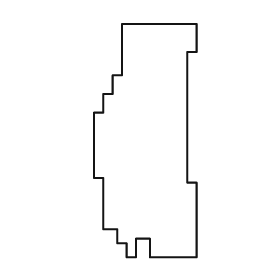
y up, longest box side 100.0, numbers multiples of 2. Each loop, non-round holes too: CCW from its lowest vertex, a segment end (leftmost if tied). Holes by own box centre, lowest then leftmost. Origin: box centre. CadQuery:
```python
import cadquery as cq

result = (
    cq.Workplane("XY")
    .moveTo(-8.0, -50.0)
    .lineTo(-4.0, -50.0)
    .lineTo(-4.0, -42.0)
    .lineTo(2.0, -42.0)
    .lineTo(2.0, -50.0)
    .lineTo(22.0, -50.0)
    .lineTo(22.0, -18.0)
    .lineTo(18.0, -18.0)
    .lineTo(18.0, 38.0)
    .lineTo(22.0, 38.0)
    .lineTo(22.0, 50.0)
    .lineTo(-10.0, 50.0)
    .lineTo(-10.0, 28.0)
    .lineTo(-14.0, 28.0)
    .lineTo(-14.0, 20.0)
    .lineTo(-18.0, 20.0)
    .lineTo(-18.0, 12.0)
    .lineTo(-22.0, 12.0)
    .lineTo(-22.0, -16.0)
    .lineTo(-18.0, -16.0)
    .lineTo(-18.0, -38.0)
    .lineTo(-12.0, -38.0)
    .lineTo(-12.0, -44.0)
    .lineTo(-8.0, -44.0)
    .close()
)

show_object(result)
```